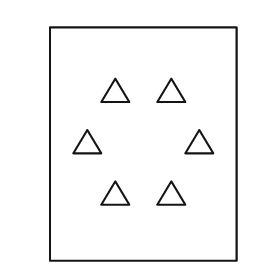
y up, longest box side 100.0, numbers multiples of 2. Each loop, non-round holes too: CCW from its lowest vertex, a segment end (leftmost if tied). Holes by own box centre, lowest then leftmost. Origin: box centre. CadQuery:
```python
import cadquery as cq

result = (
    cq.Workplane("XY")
    .moveTo(-40.0, -50.0)
    .lineTo(40.0, -50.0)
    .lineTo(40.0, 50.0)
    .lineTo(-40.0, 50.0)
    .close()
    .moveTo(-18.0, -26.0)
    .lineTo(-6.0, -26.0)
    .lineTo(-12.0, -16.0)
    .close()
    .moveTo(6.0, -26.0)
    .lineTo(18.0, -26.0)
    .lineTo(12.0, -16.0)
    .close()
    .moveTo(-30.0, -4.0)
    .lineTo(-18.0, -4.0)
    .lineTo(-24.0, 6.0)
    .close()
    .moveTo(18.0, -4.0)
    .lineTo(30.0, -4.0)
    .lineTo(24.0, 6.0)
    .close()
    .moveTo(-18.0, 18.0)
    .lineTo(-6.0, 18.0)
    .lineTo(-12.0, 28.0)
    .close()
    .moveTo(6.0, 18.0)
    .lineTo(18.0, 18.0)
    .lineTo(12.0, 28.0)
    .close()
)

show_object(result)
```